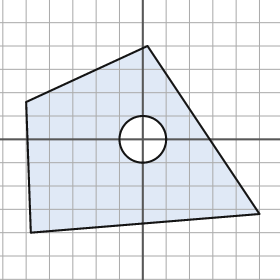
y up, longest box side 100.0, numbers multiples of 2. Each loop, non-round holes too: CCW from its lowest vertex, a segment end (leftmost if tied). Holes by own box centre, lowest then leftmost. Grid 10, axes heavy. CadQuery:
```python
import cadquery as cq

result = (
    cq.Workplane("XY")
    .moveTo(-48.0, -40.0)
    .lineTo(50.0, -32.0)
    .lineTo(2.0, 40.0)
    .lineTo(-50.0, 16.0)
    .close()
    .moveTo(0.0, 0.0)
    .circle(10.0)
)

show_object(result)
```